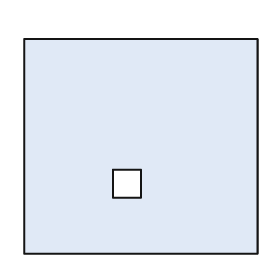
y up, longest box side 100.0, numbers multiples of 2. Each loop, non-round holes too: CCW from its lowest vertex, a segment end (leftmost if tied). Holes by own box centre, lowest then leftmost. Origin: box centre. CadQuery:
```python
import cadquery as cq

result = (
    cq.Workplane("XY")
    .moveTo(-50.0, -46.0)
    .lineTo(50.0, -46.0)
    .lineTo(50.0, 46.0)
    .lineTo(-50.0, 46.0)
    .close()
    .moveTo(-12.0, -22.0)
    .lineTo(0.0, -22.0)
    .lineTo(0.0, -10.0)
    .lineTo(-12.0, -10.0)
    .close()
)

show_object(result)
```